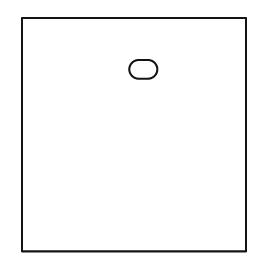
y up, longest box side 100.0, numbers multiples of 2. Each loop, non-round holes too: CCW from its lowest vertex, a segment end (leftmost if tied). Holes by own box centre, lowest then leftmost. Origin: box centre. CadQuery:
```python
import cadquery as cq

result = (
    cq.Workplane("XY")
    .moveTo(-48.0, -50.0)
    .lineTo(48.0, -50.0)
    .lineTo(48.0, 50.0)
    .lineTo(-48.0, 50.0)
    .close()
    .moveTo(2.0, 24.0)
    .lineTo(6.0, 24.0)
    .threePointArc((10.0, 28.0), (6.0, 32.0))
    .lineTo(2.0, 32.0)
    .threePointArc((-2.0, 28.0), (2.0, 24.0))
    .close()
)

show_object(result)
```